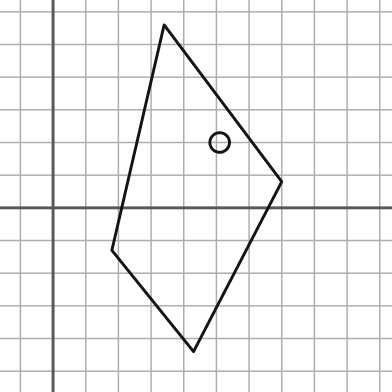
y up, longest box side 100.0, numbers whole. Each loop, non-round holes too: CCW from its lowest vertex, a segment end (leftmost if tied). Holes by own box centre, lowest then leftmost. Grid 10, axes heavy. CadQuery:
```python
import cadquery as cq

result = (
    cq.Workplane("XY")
    .moveTo(43.0, -44.0)
    .lineTo(70.0, 8.0)
    .lineTo(34.0, 56.0)
    .lineTo(18.0, -13.0)
    .close()
    .moveTo(51.0, 20.0)
    .circle(3.0)
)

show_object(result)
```